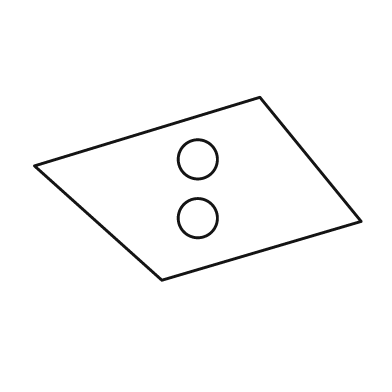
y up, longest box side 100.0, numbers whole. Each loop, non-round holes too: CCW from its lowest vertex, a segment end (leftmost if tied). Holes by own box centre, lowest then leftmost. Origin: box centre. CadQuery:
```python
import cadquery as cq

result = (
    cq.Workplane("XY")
    .moveTo(-11.0, -28.0)
    .lineTo(50.0, -10.0)
    .lineTo(19.0, 28.0)
    .lineTo(-50.0, 7.0)
    .close()
    .moveTo(0.0, -9.0)
    .circle(6.0)
    .moveTo(0.0, 9.0)
    .circle(6.0)
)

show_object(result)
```